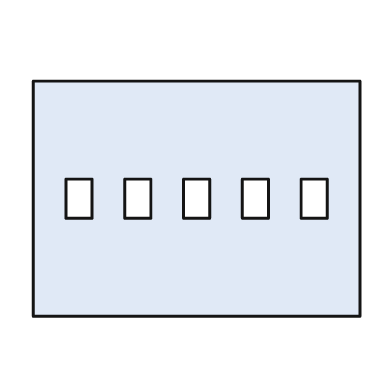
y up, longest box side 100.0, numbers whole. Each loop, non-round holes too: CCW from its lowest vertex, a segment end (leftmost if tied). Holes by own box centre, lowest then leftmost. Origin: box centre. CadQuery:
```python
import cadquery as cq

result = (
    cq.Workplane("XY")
    .moveTo(-50.0, -36.0)
    .lineTo(50.0, -36.0)
    .lineTo(50.0, 36.0)
    .lineTo(-50.0, 36.0)
    .close()
    .moveTo(-40.0, -6.0)
    .lineTo(-32.0, -6.0)
    .lineTo(-32.0, 6.0)
    .lineTo(-40.0, 6.0)
    .close()
    .moveTo(-22.0, -6.0)
    .lineTo(-14.0, -6.0)
    .lineTo(-14.0, 6.0)
    .lineTo(-22.0, 6.0)
    .close()
    .moveTo(-4.0, -6.0)
    .lineTo(4.0, -6.0)
    .lineTo(4.0, 6.0)
    .lineTo(-4.0, 6.0)
    .close()
    .moveTo(14.0, -6.0)
    .lineTo(22.0, -6.0)
    .lineTo(22.0, 6.0)
    .lineTo(14.0, 6.0)
    .close()
    .moveTo(32.0, -6.0)
    .lineTo(40.0, -6.0)
    .lineTo(40.0, 6.0)
    .lineTo(32.0, 6.0)
    .close()
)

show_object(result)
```